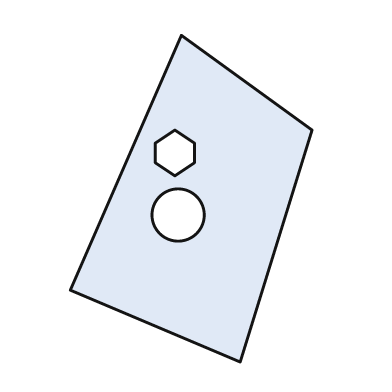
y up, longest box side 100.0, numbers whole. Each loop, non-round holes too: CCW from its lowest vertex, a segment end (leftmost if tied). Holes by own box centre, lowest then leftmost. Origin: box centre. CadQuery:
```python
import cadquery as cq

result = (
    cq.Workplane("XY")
    .moveTo(15.0, -50.0)
    .lineTo(37.0, 21.0)
    .lineTo(-3.0, 50.0)
    .lineTo(-37.0, -28.0)
    .close()
    .moveTo(-4.0, -5.0)
    .circle(8.0)
    .moveTo(-5.0, 7.0)
    .lineTo(1.0, 11.0)
    .lineTo(1.0, 17.0)
    .lineTo(-5.0, 21.0)
    .lineTo(-11.0, 17.0)
    .lineTo(-11.0, 11.0)
    .close()
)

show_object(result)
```